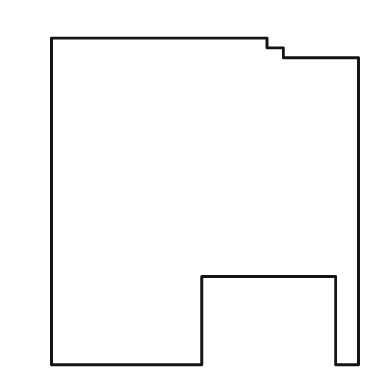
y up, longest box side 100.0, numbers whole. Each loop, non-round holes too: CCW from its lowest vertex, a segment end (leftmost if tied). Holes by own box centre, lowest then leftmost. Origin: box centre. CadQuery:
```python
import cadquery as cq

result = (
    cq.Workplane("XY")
    .moveTo(-47.0, -50.0)
    .lineTo(-1.0, -50.0)
    .lineTo(-1.0, -23.0)
    .lineTo(40.0, -23.0)
    .lineTo(40.0, -50.0)
    .lineTo(47.0, -50.0)
    .lineTo(47.0, 44.0)
    .lineTo(24.0, 44.0)
    .lineTo(24.0, 47.0)
    .lineTo(19.0, 47.0)
    .lineTo(19.0, 50.0)
    .lineTo(-47.0, 50.0)
    .close()
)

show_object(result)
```